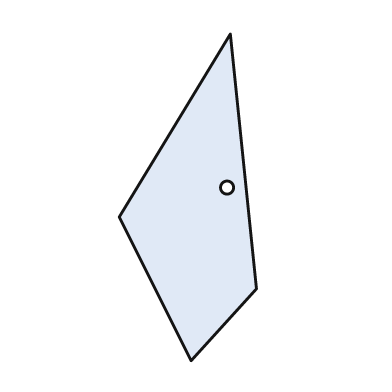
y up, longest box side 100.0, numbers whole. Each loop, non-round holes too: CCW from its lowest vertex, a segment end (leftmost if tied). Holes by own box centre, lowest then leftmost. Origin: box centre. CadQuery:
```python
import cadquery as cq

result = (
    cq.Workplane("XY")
    .moveTo(1.0, -50.0)
    .lineTo(21.0, -28.0)
    .lineTo(13.0, 50.0)
    .lineTo(-21.0, -6.0)
    .close()
    .moveTo(12.0, 3.0)
    .circle(2.0)
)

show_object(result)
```